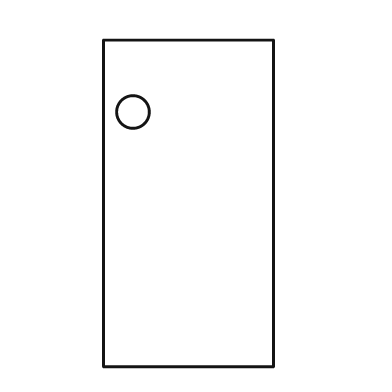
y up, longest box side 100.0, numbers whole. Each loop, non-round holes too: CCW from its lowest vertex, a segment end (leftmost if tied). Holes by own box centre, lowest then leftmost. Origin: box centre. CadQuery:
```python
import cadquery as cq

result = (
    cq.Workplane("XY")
    .moveTo(-26.0, -50.0)
    .lineTo(26.0, -50.0)
    .lineTo(26.0, 50.0)
    .lineTo(-26.0, 50.0)
    .close()
    .moveTo(-17.0, 28.0)
    .circle(5.0)
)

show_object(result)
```